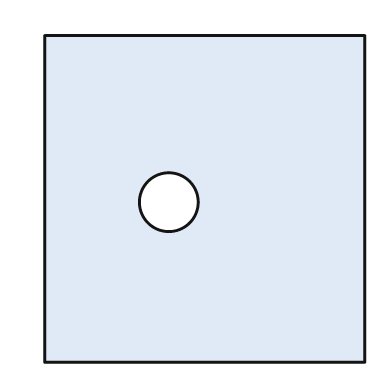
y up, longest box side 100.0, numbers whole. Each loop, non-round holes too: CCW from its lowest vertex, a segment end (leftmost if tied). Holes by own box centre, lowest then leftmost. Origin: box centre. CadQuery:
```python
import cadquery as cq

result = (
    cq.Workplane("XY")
    .moveTo(-49.0, -50.0)
    .lineTo(49.0, -50.0)
    .lineTo(49.0, 50.0)
    .lineTo(-49.0, 50.0)
    .close()
    .moveTo(-11.0, -1.0)
    .circle(9.0)
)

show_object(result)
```